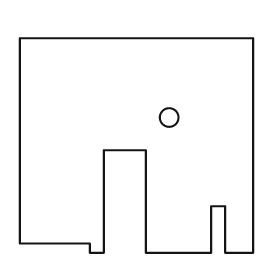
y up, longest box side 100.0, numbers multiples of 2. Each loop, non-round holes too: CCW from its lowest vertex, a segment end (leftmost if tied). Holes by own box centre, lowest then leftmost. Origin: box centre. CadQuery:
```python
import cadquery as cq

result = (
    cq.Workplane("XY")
    .moveTo(-20.0, -46.0)
    .lineTo(-14.0, -46.0)
    .lineTo(-14.0, -2.0)
    .lineTo(4.0, -2.0)
    .lineTo(4.0, -46.0)
    .lineTo(32.0, -46.0)
    .lineTo(32.0, -26.0)
    .lineTo(38.0, -26.0)
    .lineTo(38.0, -46.0)
    .lineTo(50.0, -46.0)
    .lineTo(50.0, 46.0)
    .lineTo(-50.0, 46.0)
    .lineTo(-50.0, -42.0)
    .lineTo(-20.0, -42.0)
    .close()
    .moveTo(14.0, 12.0)
    .circle(4.0)
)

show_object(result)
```